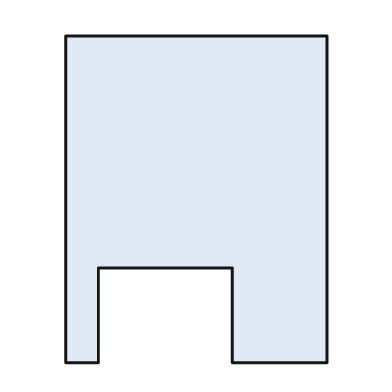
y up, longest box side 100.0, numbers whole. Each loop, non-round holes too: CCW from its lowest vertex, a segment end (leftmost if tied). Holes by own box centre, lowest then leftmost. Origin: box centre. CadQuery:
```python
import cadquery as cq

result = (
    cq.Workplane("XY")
    .moveTo(-40.0, -50.0)
    .lineTo(-30.0, -50.0)
    .lineTo(-30.0, -21.0)
    .lineTo(11.0, -21.0)
    .lineTo(11.0, -50.0)
    .lineTo(40.0, -50.0)
    .lineTo(40.0, 50.0)
    .lineTo(-40.0, 50.0)
    .close()
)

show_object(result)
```